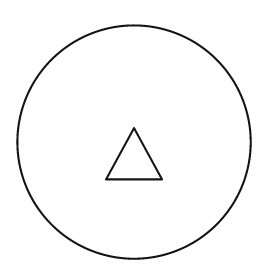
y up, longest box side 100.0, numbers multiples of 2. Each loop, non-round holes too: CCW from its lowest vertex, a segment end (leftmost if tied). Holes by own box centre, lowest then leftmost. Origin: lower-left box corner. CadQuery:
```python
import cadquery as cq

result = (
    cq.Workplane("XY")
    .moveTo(50.0, 50.0)
    .circle(50.0)
    .moveTo(38.0, 34.0)
    .lineTo(62.0, 34.0)
    .lineTo(50.0, 56.0)
    .close()
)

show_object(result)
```